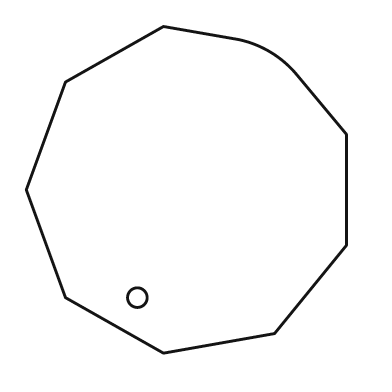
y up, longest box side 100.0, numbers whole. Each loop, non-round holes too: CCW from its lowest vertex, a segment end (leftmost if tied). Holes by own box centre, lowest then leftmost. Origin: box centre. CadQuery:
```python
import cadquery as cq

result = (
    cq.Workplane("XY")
    .moveTo(-7.0, -50.0)
    .lineTo(27.0, -44.0)
    .lineTo(49.0, -17.0)
    .lineTo(49.0, 17.0)
    .lineTo(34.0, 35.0)
    .threePointArc((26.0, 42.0), (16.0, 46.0))
    .lineTo(-7.0, 50.0)
    .lineTo(-37.0, 33.0)
    .lineTo(-49.0, 0.0)
    .lineTo(-37.0, -33.0)
    .close()
    .moveTo(-15.0, -33.0)
    .circle(3.0)
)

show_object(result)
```